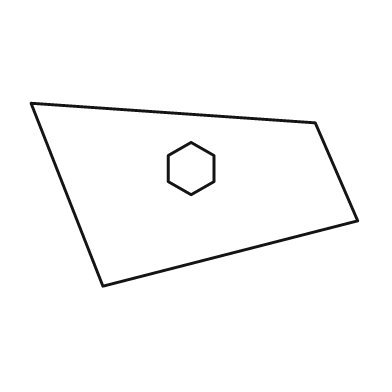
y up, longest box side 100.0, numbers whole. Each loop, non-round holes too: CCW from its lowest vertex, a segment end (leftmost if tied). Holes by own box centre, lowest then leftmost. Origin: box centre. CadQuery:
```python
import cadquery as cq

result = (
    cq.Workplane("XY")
    .moveTo(-28.0, -28.0)
    .lineTo(50.0, -8.0)
    .lineTo(37.0, 22.0)
    .lineTo(-50.0, 28.0)
    .close()
    .moveTo(-1.0, 0.0)
    .lineTo(6.0, 4.0)
    .lineTo(6.0, 12.0)
    .lineTo(-1.0, 16.0)
    .lineTo(-8.0, 12.0)
    .lineTo(-8.0, 4.0)
    .close()
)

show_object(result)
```